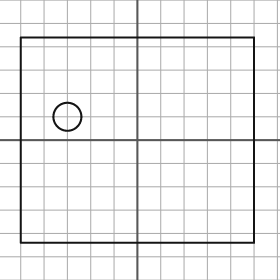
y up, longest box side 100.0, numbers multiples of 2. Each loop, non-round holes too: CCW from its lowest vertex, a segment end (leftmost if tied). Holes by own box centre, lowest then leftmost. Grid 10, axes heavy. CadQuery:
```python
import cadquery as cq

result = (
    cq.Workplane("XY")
    .moveTo(-50.0, -44.0)
    .lineTo(50.0, -44.0)
    .lineTo(50.0, 44.0)
    .lineTo(-50.0, 44.0)
    .close()
    .moveTo(-30.0, 10.0)
    .circle(6.0)
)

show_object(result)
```